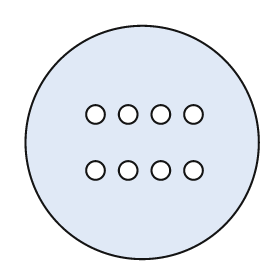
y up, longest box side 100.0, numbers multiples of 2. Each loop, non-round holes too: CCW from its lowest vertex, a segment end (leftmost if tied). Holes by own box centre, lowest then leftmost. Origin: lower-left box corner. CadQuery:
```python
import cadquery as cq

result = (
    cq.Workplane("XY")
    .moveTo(50.0, 50.0)
    .circle(50.0)
    .moveTo(30.0, 38.0)
    .circle(4.0)
    .moveTo(44.0, 38.0)
    .circle(4.0)
    .moveTo(58.0, 38.0)
    .circle(4.0)
    .moveTo(72.0, 38.0)
    .circle(4.0)
    .moveTo(30.0, 62.0)
    .circle(4.0)
    .moveTo(44.0, 62.0)
    .circle(4.0)
    .moveTo(58.0, 62.0)
    .circle(4.0)
    .moveTo(72.0, 62.0)
    .circle(4.0)
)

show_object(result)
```